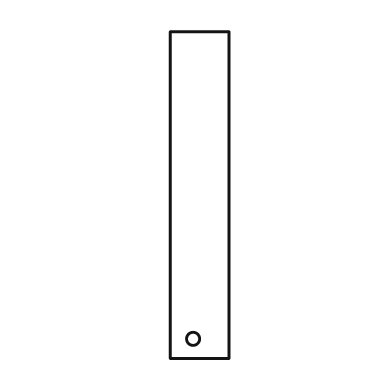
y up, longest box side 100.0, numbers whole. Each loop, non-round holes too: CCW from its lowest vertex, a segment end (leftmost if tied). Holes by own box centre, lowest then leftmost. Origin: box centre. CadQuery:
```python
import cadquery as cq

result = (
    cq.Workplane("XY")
    .moveTo(-9.0, -50.0)
    .lineTo(9.0, -50.0)
    .lineTo(9.0, 50.0)
    .lineTo(-9.0, 50.0)
    .close()
    .moveTo(-2.0, -44.0)
    .circle(2.0)
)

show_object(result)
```